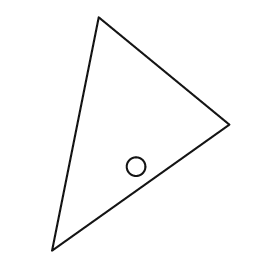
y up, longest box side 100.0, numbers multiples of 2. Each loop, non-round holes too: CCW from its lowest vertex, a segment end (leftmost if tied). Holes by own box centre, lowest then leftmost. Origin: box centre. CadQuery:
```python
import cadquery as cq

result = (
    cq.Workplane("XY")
    .moveTo(-38.0, -50.0)
    .lineTo(38.0, 4.0)
    .lineTo(-18.0, 50.0)
    .close()
    .moveTo(-2.0, -14.0)
    .circle(4.0)
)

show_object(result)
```